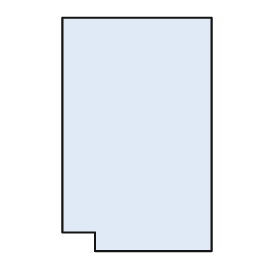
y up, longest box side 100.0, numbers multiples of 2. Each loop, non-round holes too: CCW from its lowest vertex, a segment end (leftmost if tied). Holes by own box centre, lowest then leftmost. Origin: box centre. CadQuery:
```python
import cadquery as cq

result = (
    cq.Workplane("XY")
    .moveTo(-18.0, -50.0)
    .lineTo(32.0, -50.0)
    .lineTo(32.0, 50.0)
    .lineTo(-32.0, 50.0)
    .lineTo(-32.0, -42.0)
    .lineTo(-18.0, -42.0)
    .close()
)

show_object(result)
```